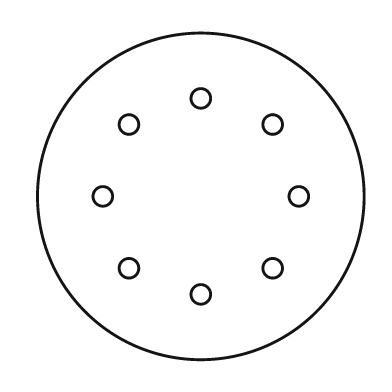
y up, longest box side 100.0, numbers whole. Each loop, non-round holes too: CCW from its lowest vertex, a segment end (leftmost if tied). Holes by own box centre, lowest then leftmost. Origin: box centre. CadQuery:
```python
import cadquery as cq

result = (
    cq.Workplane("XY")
    .moveTo(0.0, 0.0)
    .circle(50.0)
    .moveTo(0.0, -30.0)
    .circle(3.0)
    .moveTo(-22.0, -22.0)
    .circle(3.0)
    .moveTo(22.0, -22.0)
    .circle(3.0)
    .moveTo(-30.0, 0.0)
    .circle(3.0)
    .moveTo(30.0, 0.0)
    .circle(3.0)
    .moveTo(-22.0, 22.0)
    .circle(3.0)
    .moveTo(22.0, 22.0)
    .circle(3.0)
    .moveTo(0.0, 30.0)
    .circle(3.0)
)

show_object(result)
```